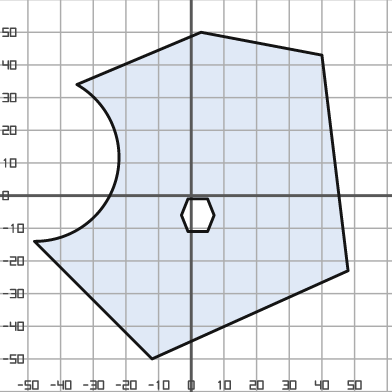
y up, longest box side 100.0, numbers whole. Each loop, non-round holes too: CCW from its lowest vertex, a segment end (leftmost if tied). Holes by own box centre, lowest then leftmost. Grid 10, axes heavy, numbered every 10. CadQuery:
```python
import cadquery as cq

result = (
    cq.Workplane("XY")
    .moveTo(-12.0, -50.0)
    .lineTo(48.0, -23.0)
    .lineTo(40.0, 43.0)
    .lineTo(3.0, 50.0)
    .lineTo(-35.0, 34.0)
    .threePointArc((-23.0, 5.0), (-48.0, -14.0))
    .close()
    .moveTo(-1.0, -11.0)
    .lineTo(5.0, -11.0)
    .lineTo(7.0, -6.0)
    .lineTo(5.0, -1.0)
    .lineTo(-1.0, -1.0)
    .lineTo(-3.0, -6.0)
    .close()
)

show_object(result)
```